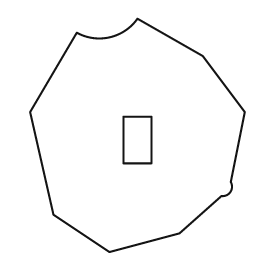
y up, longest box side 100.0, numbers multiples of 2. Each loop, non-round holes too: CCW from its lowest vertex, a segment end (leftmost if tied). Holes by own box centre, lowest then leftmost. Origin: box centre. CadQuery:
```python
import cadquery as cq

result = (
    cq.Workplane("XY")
    .moveTo(-12.0, -50.0)
    .lineTo(18.0, -42.0)
    .lineTo(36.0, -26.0)
    .threePointArc((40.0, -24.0), (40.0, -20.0))
    .lineTo(46.0, 10.0)
    .lineTo(28.0, 34.0)
    .lineTo(0.0, 50.0)
    .threePointArc((-12.0, 42.0), (-26.0, 44.0))
    .lineTo(-46.0, 10.0)
    .lineTo(-36.0, -34.0)
    .close()
    .moveTo(-6.0, -12.0)
    .lineTo(6.0, -12.0)
    .lineTo(6.0, 8.0)
    .lineTo(-6.0, 8.0)
    .close()
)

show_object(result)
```